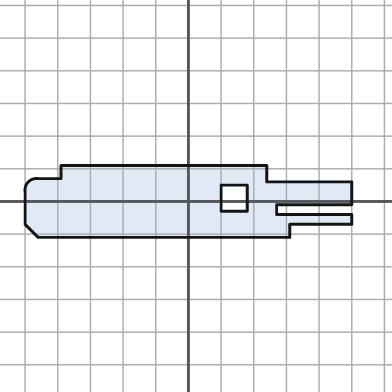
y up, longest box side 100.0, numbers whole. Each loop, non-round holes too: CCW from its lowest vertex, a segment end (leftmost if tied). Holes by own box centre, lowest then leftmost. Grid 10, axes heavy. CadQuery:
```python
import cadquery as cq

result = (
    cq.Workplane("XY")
    .moveTo(-46.0, -11.0)
    .lineTo(31.0, -11.0)
    .lineTo(31.0, -7.0)
    .lineTo(50.0, -7.0)
    .lineTo(50.0, -4.0)
    .lineTo(27.0, -4.0)
    .lineTo(27.0, -1.0)
    .lineTo(50.0, -1.0)
    .lineTo(50.0, 6.0)
    .lineTo(24.0, 6.0)
    .lineTo(24.0, 11.0)
    .lineTo(-39.0, 11.0)
    .lineTo(-39.0, 7.0)
    .lineTo(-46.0, 7.0)
    .threePointArc((-49.0, 6.0), (-50.0, 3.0))
    .lineTo(-50.0, -7.0)
    .close()
    .moveTo(10.0, -3.0)
    .lineTo(18.0, -3.0)
    .lineTo(18.0, 5.0)
    .lineTo(10.0, 5.0)
    .close()
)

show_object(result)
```